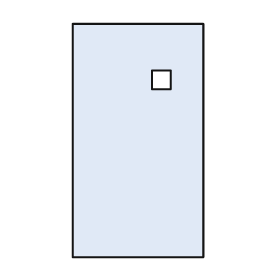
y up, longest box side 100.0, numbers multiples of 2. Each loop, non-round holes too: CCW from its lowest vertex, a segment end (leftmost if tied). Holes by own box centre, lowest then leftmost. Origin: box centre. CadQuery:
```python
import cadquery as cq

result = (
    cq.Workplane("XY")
    .moveTo(-28.0, -50.0)
    .lineTo(28.0, -50.0)
    .lineTo(28.0, 50.0)
    .lineTo(-28.0, 50.0)
    .close()
    .moveTo(6.0, 22.0)
    .lineTo(14.0, 22.0)
    .lineTo(14.0, 30.0)
    .lineTo(6.0, 30.0)
    .close()
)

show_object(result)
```